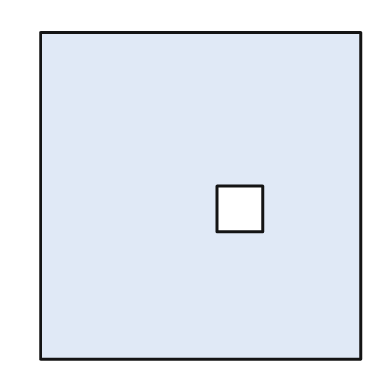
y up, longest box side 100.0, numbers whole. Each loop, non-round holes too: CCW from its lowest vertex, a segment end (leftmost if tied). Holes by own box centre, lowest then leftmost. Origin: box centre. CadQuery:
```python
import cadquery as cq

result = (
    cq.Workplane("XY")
    .moveTo(-49.0, -50.0)
    .lineTo(49.0, -50.0)
    .lineTo(49.0, 50.0)
    .lineTo(-49.0, 50.0)
    .close()
    .moveTo(5.0, -11.0)
    .lineTo(19.0, -11.0)
    .lineTo(19.0, 3.0)
    .lineTo(5.0, 3.0)
    .close()
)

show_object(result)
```